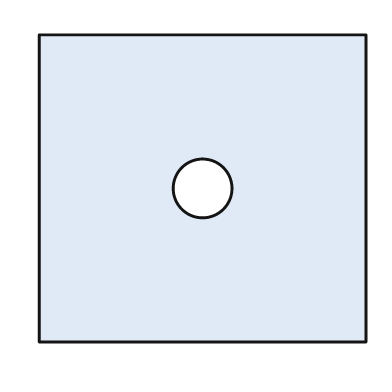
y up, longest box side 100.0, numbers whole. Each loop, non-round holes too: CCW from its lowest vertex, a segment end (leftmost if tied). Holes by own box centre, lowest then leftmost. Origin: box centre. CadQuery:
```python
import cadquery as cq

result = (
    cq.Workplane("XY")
    .moveTo(-50.0, -47.0)
    .lineTo(50.0, -47.0)
    .lineTo(50.0, 47.0)
    .lineTo(-50.0, 47.0)
    .close()
    .moveTo(0.0, 0.0)
    .circle(9.0)
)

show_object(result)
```